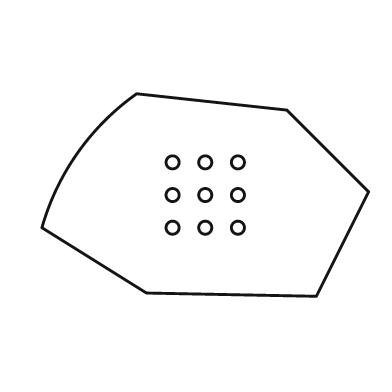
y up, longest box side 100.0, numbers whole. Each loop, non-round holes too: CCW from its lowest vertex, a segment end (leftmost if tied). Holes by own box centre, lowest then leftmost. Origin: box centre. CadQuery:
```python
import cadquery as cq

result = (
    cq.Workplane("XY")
    .moveTo(34.0, -31.0)
    .lineTo(50.0, 1.0)
    .lineTo(25.0, 26.0)
    .lineTo(-21.0, 31.0)
    .threePointArc((-39.0, 13.0), (-50.0, -10.0))
    .lineTo(-18.0, -30.0)
    .close()
    .moveTo(-10.0, -10.0)
    .circle(2.0)
    .moveTo(0.0, -10.0)
    .circle(2.0)
    .moveTo(10.0, -10.0)
    .circle(2.0)
    .moveTo(-10.0, 0.0)
    .circle(2.0)
    .moveTo(0.0, 0.0)
    .circle(2.0)
    .moveTo(10.0, 0.0)
    .circle(2.0)
    .moveTo(-10.0, 10.0)
    .circle(2.0)
    .moveTo(0.0, 10.0)
    .circle(2.0)
    .moveTo(10.0, 10.0)
    .circle(2.0)
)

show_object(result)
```